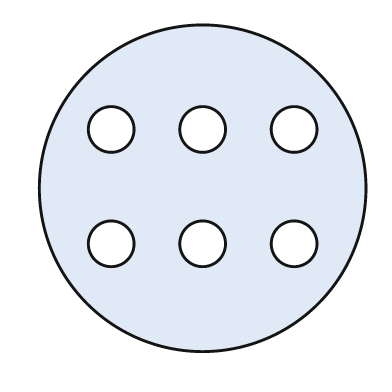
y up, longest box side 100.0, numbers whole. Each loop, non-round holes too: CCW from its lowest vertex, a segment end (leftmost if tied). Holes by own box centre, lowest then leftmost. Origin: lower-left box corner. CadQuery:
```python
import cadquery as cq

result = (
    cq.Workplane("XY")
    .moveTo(50.0, 50.0)
    .circle(50.0)
    .moveTo(22.0, 33.0)
    .circle(7.0)
    .moveTo(50.0, 33.0)
    .circle(7.0)
    .moveTo(78.0, 33.0)
    .circle(7.0)
    .moveTo(22.0, 68.0)
    .circle(7.0)
    .moveTo(50.0, 68.0)
    .circle(7.0)
    .moveTo(78.0, 68.0)
    .circle(7.0)
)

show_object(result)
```